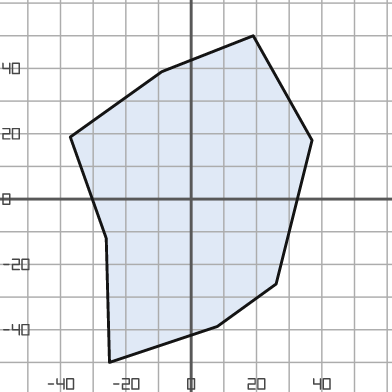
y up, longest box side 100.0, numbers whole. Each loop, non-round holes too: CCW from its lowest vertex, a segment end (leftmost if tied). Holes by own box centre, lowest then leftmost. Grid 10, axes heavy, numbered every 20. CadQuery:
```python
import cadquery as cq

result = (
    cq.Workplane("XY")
    .moveTo(-25.0, -50.0)
    .lineTo(8.0, -39.0)
    .lineTo(26.0, -26.0)
    .lineTo(37.0, 18.0)
    .lineTo(19.0, 50.0)
    .lineTo(-9.0, 39.0)
    .lineTo(-37.0, 19.0)
    .lineTo(-26.0, -12.0)
    .close()
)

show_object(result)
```